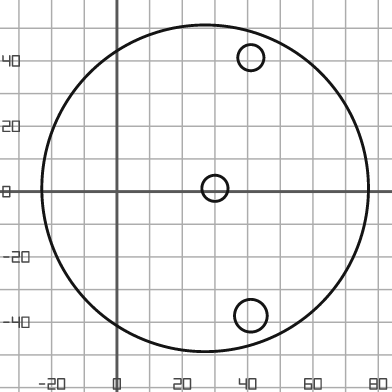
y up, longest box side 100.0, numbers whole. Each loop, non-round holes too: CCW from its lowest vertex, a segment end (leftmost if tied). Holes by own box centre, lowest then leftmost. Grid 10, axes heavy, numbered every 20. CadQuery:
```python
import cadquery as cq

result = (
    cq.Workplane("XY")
    .moveTo(27.0, 1.0)
    .circle(50.0)
    .moveTo(41.0, -38.0)
    .circle(5.0)
    .moveTo(30.0, 1.0)
    .circle(4.0)
    .moveTo(41.0, 41.0)
    .circle(4.0)
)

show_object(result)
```